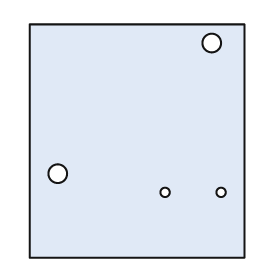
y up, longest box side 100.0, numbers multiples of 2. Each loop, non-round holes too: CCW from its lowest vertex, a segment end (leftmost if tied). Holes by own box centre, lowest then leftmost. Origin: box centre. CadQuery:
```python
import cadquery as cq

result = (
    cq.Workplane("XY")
    .moveTo(-46.0, -50.0)
    .lineTo(46.0, -50.0)
    .lineTo(46.0, 50.0)
    .lineTo(-46.0, 50.0)
    .close()
    .moveTo(12.0, -22.0)
    .circle(2.0)
    .moveTo(36.0, -22.0)
    .circle(2.0)
    .moveTo(-34.0, -14.0)
    .circle(4.0)
    .moveTo(32.0, 42.0)
    .circle(4.0)
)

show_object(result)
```